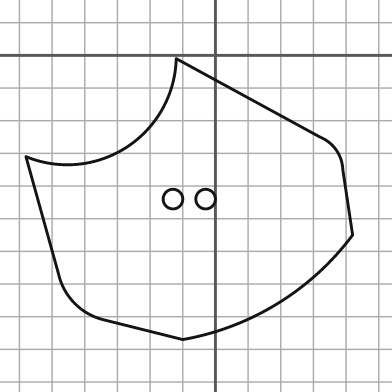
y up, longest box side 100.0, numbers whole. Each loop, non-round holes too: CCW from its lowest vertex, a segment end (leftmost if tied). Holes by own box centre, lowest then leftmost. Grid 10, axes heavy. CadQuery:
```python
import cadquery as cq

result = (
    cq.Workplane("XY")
    .moveTo(-10.0, -87.0)
    .threePointArc((19.0, -76.0), (42.0, -55.0))
    .lineTo(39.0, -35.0)
    .threePointArc((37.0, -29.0), (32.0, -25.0))
    .lineTo(-12.0, -1.0)
    .threePointArc((-27.0, -28.0), (-58.0, -31.0))
    .lineTo(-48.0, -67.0)
    .threePointArc((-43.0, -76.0), (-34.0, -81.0))
    .close()
    .moveTo(-13.0, -44.0)
    .circle(3.0)
    .moveTo(-3.0, -44.0)
    .circle(3.0)
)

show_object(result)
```